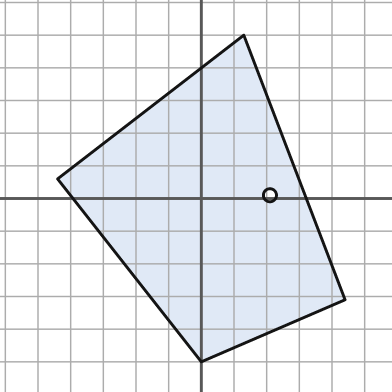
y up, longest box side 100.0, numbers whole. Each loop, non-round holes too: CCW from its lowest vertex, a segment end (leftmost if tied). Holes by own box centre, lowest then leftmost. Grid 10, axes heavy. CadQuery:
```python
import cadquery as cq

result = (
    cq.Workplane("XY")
    .moveTo(0.0, -50.0)
    .lineTo(44.0, -31.0)
    .lineTo(13.0, 50.0)
    .lineTo(-44.0, 6.0)
    .close()
    .moveTo(21.0, 1.0)
    .circle(2.0)
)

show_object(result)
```